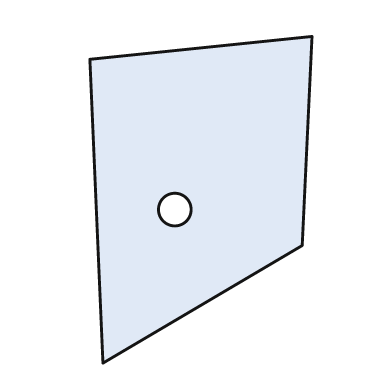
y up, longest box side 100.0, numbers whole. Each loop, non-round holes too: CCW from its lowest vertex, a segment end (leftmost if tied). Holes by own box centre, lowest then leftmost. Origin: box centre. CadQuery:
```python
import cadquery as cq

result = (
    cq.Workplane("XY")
    .moveTo(-30.0, -50.0)
    .lineTo(31.0, -14.0)
    .lineTo(34.0, 50.0)
    .lineTo(-34.0, 43.0)
    .close()
    .moveTo(-8.0, -3.0)
    .circle(5.0)
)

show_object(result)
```